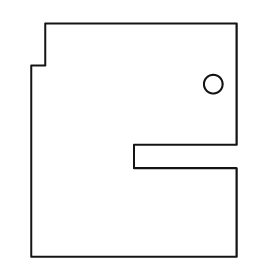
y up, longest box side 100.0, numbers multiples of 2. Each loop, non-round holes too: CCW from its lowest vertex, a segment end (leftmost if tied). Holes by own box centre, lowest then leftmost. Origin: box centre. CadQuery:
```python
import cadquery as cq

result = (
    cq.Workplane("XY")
    .moveTo(-44.0, -50.0)
    .lineTo(44.0, -50.0)
    .lineTo(44.0, -12.0)
    .lineTo(0.0, -12.0)
    .lineTo(0.0, -2.0)
    .lineTo(44.0, -2.0)
    .lineTo(44.0, 50.0)
    .lineTo(-38.0, 50.0)
    .lineTo(-38.0, 32.0)
    .lineTo(-44.0, 32.0)
    .close()
    .moveTo(34.0, 24.0)
    .circle(4.0)
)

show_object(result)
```